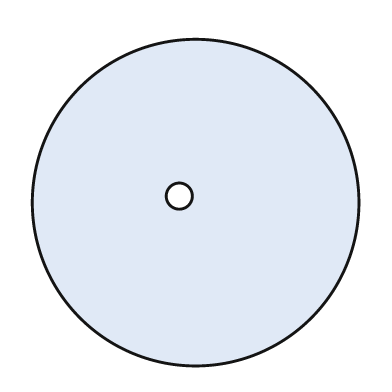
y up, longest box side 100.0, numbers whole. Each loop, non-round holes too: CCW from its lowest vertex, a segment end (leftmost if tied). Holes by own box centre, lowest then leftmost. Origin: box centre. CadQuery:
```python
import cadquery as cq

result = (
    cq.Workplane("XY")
    .moveTo(0.0, 0.0)
    .circle(50.0)
    .moveTo(-5.0, 2.0)
    .circle(4.0)
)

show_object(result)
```